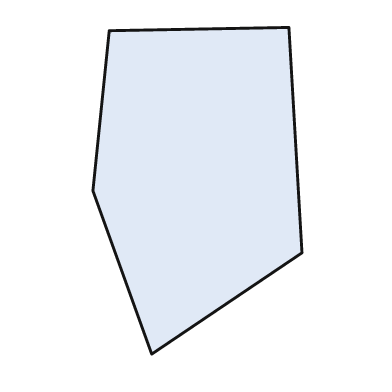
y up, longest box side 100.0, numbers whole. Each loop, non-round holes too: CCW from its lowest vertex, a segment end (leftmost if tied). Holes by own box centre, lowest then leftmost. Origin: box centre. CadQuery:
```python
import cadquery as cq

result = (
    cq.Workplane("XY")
    .moveTo(-14.0, -50.0)
    .lineTo(32.0, -19.0)
    .lineTo(28.0, 50.0)
    .lineTo(-27.0, 49.0)
    .lineTo(-32.0, 0.0)
    .close()
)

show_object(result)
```